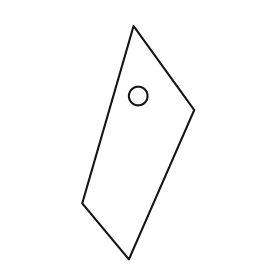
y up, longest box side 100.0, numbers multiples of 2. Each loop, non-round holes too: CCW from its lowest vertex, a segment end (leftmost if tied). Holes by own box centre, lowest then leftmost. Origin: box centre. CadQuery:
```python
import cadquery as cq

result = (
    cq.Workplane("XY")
    .moveTo(-4.0, -50.0)
    .lineTo(24.0, 14.0)
    .lineTo(-2.0, 50.0)
    .lineTo(-24.0, -26.0)
    .close()
    .moveTo(0.0, 20.0)
    .circle(4.0)
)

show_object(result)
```